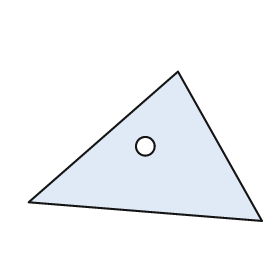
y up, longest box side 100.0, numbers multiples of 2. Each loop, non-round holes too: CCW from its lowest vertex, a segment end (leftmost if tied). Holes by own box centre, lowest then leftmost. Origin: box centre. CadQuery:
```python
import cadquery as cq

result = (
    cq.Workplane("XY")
    .moveTo(50.0, -32.0)
    .lineTo(14.0, 32.0)
    .lineTo(-50.0, -24.0)
    .close()
    .moveTo(0.0, 0.0)
    .circle(4.0)
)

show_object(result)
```